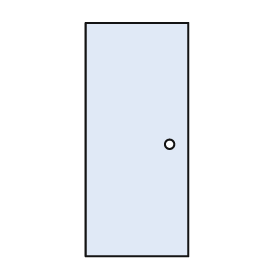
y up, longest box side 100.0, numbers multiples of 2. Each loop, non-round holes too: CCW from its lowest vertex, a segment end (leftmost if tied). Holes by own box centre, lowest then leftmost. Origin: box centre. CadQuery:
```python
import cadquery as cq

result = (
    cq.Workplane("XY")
    .moveTo(-22.0, -50.0)
    .lineTo(22.0, -50.0)
    .lineTo(22.0, 50.0)
    .lineTo(-22.0, 50.0)
    .close()
    .moveTo(14.0, -2.0)
    .circle(2.0)
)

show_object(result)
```